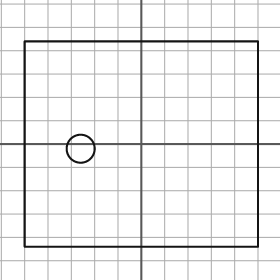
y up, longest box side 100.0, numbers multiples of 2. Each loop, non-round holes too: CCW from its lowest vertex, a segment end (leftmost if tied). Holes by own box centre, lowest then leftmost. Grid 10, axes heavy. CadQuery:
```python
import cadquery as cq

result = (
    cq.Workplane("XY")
    .moveTo(-50.0, -44.0)
    .lineTo(50.0, -44.0)
    .lineTo(50.0, 44.0)
    .lineTo(-50.0, 44.0)
    .close()
    .moveTo(-26.0, -2.0)
    .circle(6.0)
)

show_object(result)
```